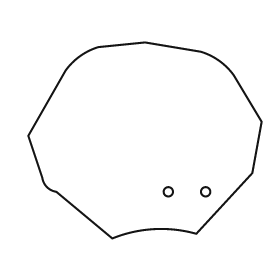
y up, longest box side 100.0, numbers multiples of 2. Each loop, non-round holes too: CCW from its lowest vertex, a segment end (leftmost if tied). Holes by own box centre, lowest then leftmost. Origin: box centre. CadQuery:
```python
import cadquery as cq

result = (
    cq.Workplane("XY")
    .moveTo(-14.0, -42.0)
    .threePointArc((4.0, -38.0), (22.0, -40.0))
    .lineTo(46.0, -14.0)
    .lineTo(50.0, 8.0)
    .lineTo(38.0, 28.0)
    .threePointArc((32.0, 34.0), (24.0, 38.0))
    .lineTo(0.0, 42.0)
    .lineTo(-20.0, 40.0)
    .threePointArc((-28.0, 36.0), (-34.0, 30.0))
    .lineTo(-50.0, 2.0)
    .lineTo(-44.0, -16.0)
    .threePointArc((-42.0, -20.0), (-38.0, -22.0))
    .close()
    .moveTo(10.0, -22.0)
    .circle(2.0)
    .moveTo(26.0, -22.0)
    .circle(2.0)
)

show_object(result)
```